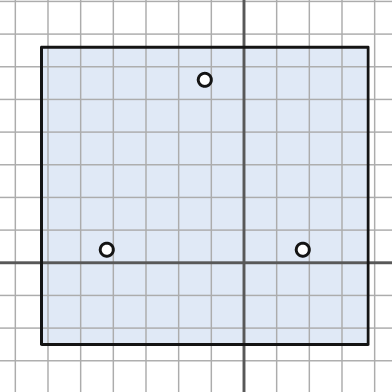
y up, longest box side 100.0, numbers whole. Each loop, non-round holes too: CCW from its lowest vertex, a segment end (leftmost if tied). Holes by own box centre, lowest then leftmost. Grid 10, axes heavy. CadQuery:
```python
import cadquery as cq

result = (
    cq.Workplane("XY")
    .moveTo(-62.0, -25.0)
    .lineTo(38.0, -25.0)
    .lineTo(38.0, 66.0)
    .lineTo(-62.0, 66.0)
    .close()
    .moveTo(-42.0, 4.0)
    .circle(2.0)
    .moveTo(18.0, 4.0)
    .circle(2.0)
    .moveTo(-12.0, 56.0)
    .circle(2.0)
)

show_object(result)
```